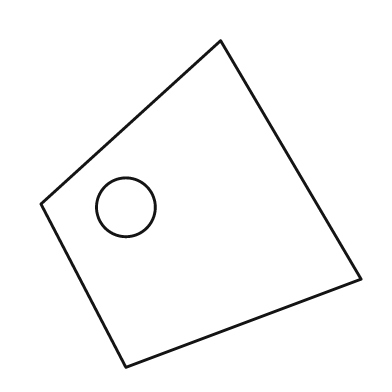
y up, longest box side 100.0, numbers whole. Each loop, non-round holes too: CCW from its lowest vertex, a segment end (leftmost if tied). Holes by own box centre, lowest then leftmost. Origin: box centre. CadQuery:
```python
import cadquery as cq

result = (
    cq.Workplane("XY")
    .moveTo(-23.0, -50.0)
    .lineTo(49.0, -23.0)
    .lineTo(6.0, 50.0)
    .lineTo(-49.0, 0.0)
    .close()
    .moveTo(-23.0, -1.0)
    .circle(9.0)
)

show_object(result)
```